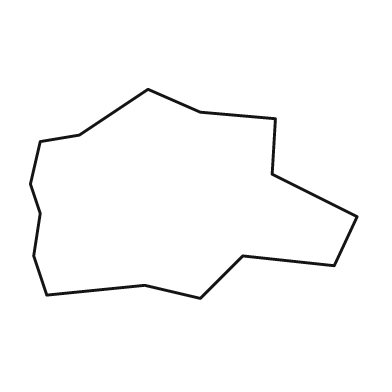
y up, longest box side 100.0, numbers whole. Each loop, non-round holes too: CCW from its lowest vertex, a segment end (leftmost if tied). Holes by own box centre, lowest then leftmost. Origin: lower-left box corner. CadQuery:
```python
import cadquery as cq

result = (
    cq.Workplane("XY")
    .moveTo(52.0, 0.0)
    .lineTo(65.0, 13.0)
    .lineTo(93.0, 10.0)
    .lineTo(100.0, 25.0)
    .lineTo(74.0, 38.0)
    .lineTo(75.0, 55.0)
    .lineTo(52.0, 57.0)
    .lineTo(36.0, 64.0)
    .lineTo(15.0, 50.0)
    .lineTo(3.0, 48.0)
    .lineTo(0.0, 35.0)
    .lineTo(3.0, 26.0)
    .lineTo(1.0, 13.0)
    .lineTo(5.0, 1.0)
    .lineTo(35.0, 4.0)
    .close()
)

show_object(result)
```